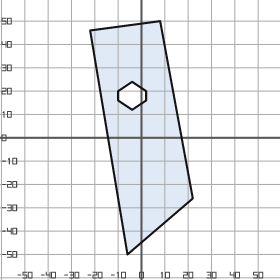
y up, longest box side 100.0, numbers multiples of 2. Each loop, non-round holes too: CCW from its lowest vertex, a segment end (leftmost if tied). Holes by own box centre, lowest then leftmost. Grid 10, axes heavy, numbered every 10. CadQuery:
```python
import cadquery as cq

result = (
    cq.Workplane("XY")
    .moveTo(-6.0, -50.0)
    .lineTo(22.0, -26.0)
    .lineTo(8.0, 50.0)
    .lineTo(-22.0, 46.0)
    .close()
    .moveTo(-4.0, 12.0)
    .lineTo(2.0, 16.0)
    .lineTo(2.0, 20.0)
    .lineTo(-4.0, 24.0)
    .lineTo(-10.0, 20.0)
    .lineTo(-10.0, 16.0)
    .close()
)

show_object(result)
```